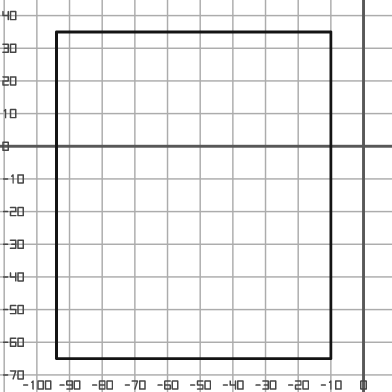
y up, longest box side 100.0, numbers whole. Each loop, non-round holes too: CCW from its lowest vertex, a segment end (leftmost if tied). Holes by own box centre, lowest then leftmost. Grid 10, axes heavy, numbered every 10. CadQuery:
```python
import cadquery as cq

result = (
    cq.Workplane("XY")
    .moveTo(-94.0, -65.0)
    .lineTo(-10.0, -65.0)
    .lineTo(-10.0, 35.0)
    .lineTo(-94.0, 35.0)
    .close()
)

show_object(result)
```